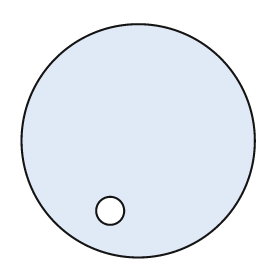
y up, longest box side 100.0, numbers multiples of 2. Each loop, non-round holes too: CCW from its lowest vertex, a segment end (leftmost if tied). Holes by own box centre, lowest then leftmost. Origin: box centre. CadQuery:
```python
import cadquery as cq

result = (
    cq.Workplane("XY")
    .moveTo(0.0, 0.0)
    .circle(50.0)
    .moveTo(-12.0, -30.0)
    .circle(6.0)
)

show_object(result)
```